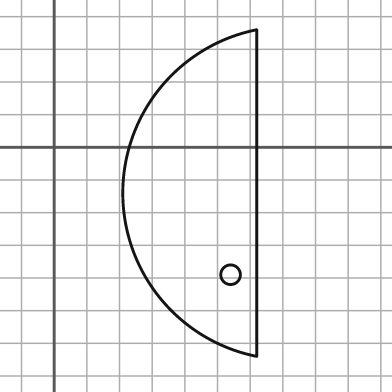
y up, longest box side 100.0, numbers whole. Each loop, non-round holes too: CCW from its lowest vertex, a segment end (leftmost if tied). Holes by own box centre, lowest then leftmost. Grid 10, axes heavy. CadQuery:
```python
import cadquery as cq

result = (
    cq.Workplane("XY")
    .moveTo(62.0, -64.0)
    .lineTo(62.0, 36.0)
    .threePointArc((21.0, -14.0), (62.0, -64.0))
    .close()
    .moveTo(54.0, -39.0)
    .circle(3.0)
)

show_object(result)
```